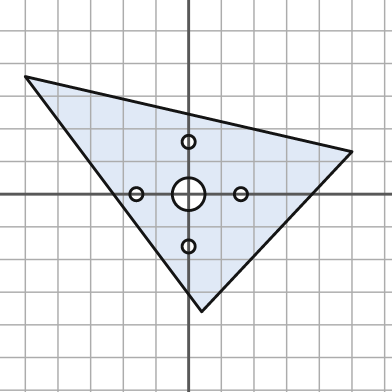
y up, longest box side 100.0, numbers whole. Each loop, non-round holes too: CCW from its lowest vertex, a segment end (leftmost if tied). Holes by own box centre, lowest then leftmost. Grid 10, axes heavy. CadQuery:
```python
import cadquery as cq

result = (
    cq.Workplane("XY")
    .moveTo(4.0, -36.0)
    .lineTo(50.0, 13.0)
    .lineTo(-50.0, 36.0)
    .close()
    .moveTo(0.0, -16.0)
    .circle(2.0)
    .moveTo(-16.0, 0.0)
    .circle(2.0)
    .moveTo(0.0, 0.0)
    .circle(5.0)
    .moveTo(16.0, 0.0)
    .circle(2.0)
    .moveTo(0.0, 16.0)
    .circle(2.0)
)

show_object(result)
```